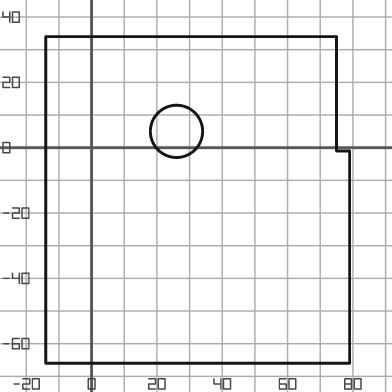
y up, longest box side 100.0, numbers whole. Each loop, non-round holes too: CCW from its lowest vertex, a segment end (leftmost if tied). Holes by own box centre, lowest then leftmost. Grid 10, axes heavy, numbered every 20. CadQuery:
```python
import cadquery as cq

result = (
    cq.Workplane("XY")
    .moveTo(-14.0, -66.0)
    .lineTo(79.0, -66.0)
    .lineTo(79.0, -1.0)
    .lineTo(75.0, -1.0)
    .lineTo(75.0, 34.0)
    .lineTo(-14.0, 34.0)
    .close()
    .moveTo(26.0, 5.0)
    .circle(8.0)
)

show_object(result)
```